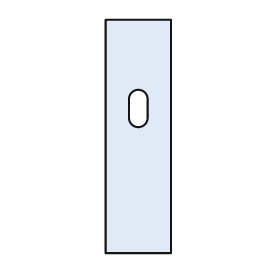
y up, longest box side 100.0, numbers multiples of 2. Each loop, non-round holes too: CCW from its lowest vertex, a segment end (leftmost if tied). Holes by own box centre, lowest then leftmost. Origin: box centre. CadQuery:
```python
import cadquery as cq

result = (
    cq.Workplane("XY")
    .moveTo(-14.0, -50.0)
    .lineTo(14.0, -50.0)
    .lineTo(14.0, 50.0)
    .lineTo(-14.0, 50.0)
    .close()
    .moveTo(-4.0, 8.0)
    .threePointArc((0.0, 4.0), (4.0, 8.0))
    .lineTo(4.0, 16.0)
    .threePointArc((0.0, 20.0), (-4.0, 16.0))
    .close()
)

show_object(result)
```